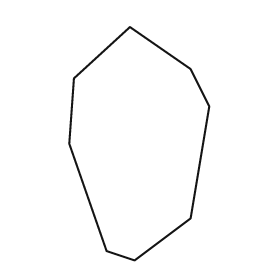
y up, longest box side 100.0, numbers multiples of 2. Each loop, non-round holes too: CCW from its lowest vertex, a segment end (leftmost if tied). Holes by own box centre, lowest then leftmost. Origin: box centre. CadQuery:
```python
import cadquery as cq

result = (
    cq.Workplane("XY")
    .moveTo(-2.0, -50.0)
    .lineTo(22.0, -32.0)
    .lineTo(30.0, 16.0)
    .lineTo(22.0, 32.0)
    .lineTo(-4.0, 50.0)
    .lineTo(-28.0, 28.0)
    .lineTo(-30.0, 0.0)
    .lineTo(-14.0, -46.0)
    .close()
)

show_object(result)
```